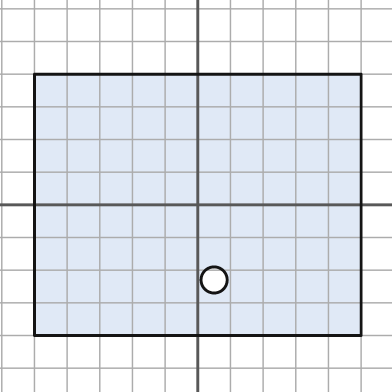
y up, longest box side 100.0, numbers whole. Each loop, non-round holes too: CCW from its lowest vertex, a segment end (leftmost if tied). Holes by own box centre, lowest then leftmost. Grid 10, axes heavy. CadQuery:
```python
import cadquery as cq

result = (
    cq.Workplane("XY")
    .moveTo(-50.0, -40.0)
    .lineTo(50.0, -40.0)
    .lineTo(50.0, 40.0)
    .lineTo(-50.0, 40.0)
    .close()
    .moveTo(5.0, -23.0)
    .circle(4.0)
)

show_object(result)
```